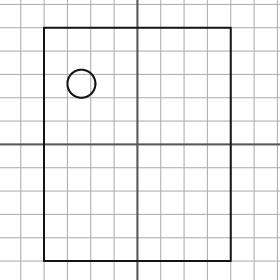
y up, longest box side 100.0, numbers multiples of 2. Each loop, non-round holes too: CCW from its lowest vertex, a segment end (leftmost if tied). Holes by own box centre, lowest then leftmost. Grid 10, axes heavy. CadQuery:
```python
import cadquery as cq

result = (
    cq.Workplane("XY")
    .moveTo(-40.0, -50.0)
    .lineTo(40.0, -50.0)
    .lineTo(40.0, 50.0)
    .lineTo(-40.0, 50.0)
    .close()
    .moveTo(-24.0, 26.0)
    .circle(6.0)
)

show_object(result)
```